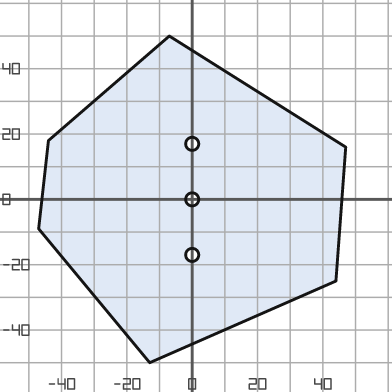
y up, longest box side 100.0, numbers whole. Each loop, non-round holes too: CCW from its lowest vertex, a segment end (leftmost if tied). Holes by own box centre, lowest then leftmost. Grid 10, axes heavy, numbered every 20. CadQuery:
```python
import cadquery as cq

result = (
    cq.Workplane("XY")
    .moveTo(-13.0, -50.0)
    .lineTo(44.0, -25.0)
    .lineTo(47.0, 16.0)
    .lineTo(-7.0, 50.0)
    .lineTo(-44.0, 18.0)
    .lineTo(-47.0, -9.0)
    .close()
    .moveTo(0.0, -17.0)
    .circle(2.0)
    .moveTo(0.0, 0.0)
    .circle(2.0)
    .moveTo(0.0, 17.0)
    .circle(2.0)
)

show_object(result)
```